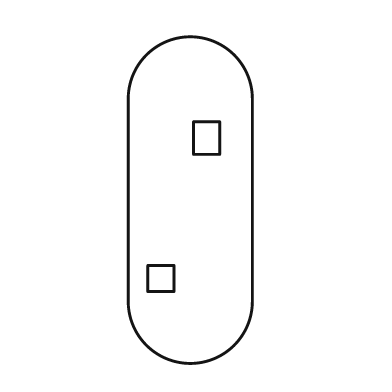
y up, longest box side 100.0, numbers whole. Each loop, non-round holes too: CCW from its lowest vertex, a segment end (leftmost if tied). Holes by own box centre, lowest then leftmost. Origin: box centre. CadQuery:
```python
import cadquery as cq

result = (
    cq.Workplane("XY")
    .moveTo(-19.0, -31.0)
    .threePointArc((0.0, -50.0), (19.0, -31.0))
    .lineTo(19.0, 31.0)
    .threePointArc((0.0, 50.0), (-19.0, 31.0))
    .close()
    .moveTo(-13.0, -28.0)
    .lineTo(-5.0, -28.0)
    .lineTo(-5.0, -20.0)
    .lineTo(-13.0, -20.0)
    .close()
    .moveTo(1.0, 14.0)
    .lineTo(9.0, 14.0)
    .lineTo(9.0, 24.0)
    .lineTo(1.0, 24.0)
    .close()
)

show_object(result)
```